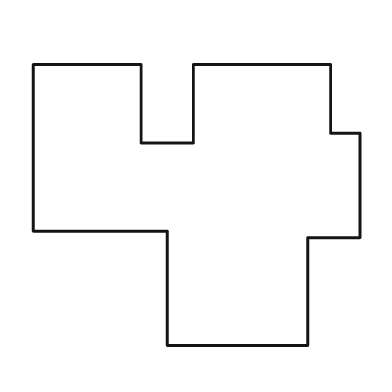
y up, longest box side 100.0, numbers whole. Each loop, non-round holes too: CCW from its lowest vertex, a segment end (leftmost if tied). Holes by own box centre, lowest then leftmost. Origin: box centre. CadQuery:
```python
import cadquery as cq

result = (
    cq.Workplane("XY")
    .moveTo(-9.0, -43.0)
    .lineTo(34.0, -43.0)
    .lineTo(34.0, -10.0)
    .lineTo(50.0, -10.0)
    .lineTo(50.0, 22.0)
    .lineTo(41.0, 22.0)
    .lineTo(41.0, 43.0)
    .lineTo(-1.0, 43.0)
    .lineTo(-1.0, 19.0)
    .lineTo(-17.0, 19.0)
    .lineTo(-17.0, 43.0)
    .lineTo(-50.0, 43.0)
    .lineTo(-50.0, -8.0)
    .lineTo(-9.0, -8.0)
    .close()
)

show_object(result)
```